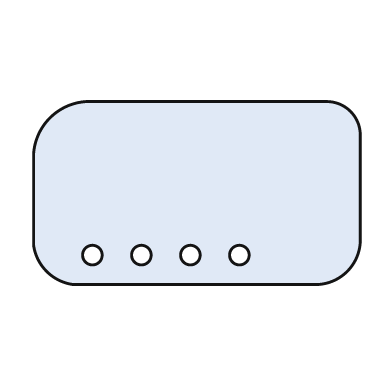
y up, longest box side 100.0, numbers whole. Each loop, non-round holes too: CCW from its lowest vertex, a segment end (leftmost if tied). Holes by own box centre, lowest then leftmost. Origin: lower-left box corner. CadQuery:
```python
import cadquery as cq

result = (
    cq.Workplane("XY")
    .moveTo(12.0, 0.0)
    .lineTo(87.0, 0.0)
    .threePointArc((96.0, 4.0), (100.0, 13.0))
    .lineTo(100.0, 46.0)
    .threePointArc((97.0, 53.0), (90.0, 56.0))
    .lineTo(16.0, 56.0)
    .threePointArc((5.0, 51.0), (0.0, 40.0))
    .lineTo(0.0, 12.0)
    .threePointArc((4.0, 4.0), (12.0, 0.0))
    .close()
    .moveTo(18.0, 9.0)
    .circle(3.0)
    .moveTo(33.0, 9.0)
    .circle(3.0)
    .moveTo(48.0, 9.0)
    .circle(3.0)
    .moveTo(63.0, 9.0)
    .circle(3.0)
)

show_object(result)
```